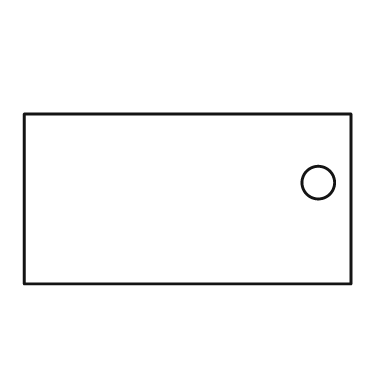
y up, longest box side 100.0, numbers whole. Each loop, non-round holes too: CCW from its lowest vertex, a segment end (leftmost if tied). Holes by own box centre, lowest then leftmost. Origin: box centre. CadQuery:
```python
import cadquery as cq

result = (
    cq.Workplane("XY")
    .moveTo(-50.0, -26.0)
    .lineTo(50.0, -26.0)
    .lineTo(50.0, 26.0)
    .lineTo(-50.0, 26.0)
    .close()
    .moveTo(40.0, 5.0)
    .circle(5.0)
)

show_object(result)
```